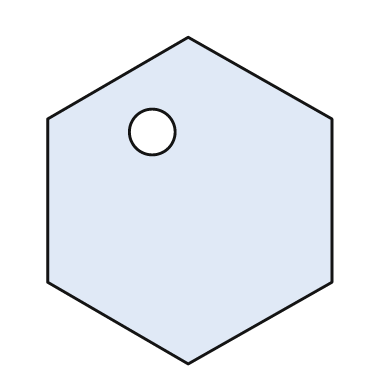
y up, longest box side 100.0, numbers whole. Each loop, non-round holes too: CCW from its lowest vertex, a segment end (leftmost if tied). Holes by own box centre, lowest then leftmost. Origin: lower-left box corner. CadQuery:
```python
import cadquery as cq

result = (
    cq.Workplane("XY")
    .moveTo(43.0, 0.0)
    .lineTo(87.0, 25.0)
    .lineTo(87.0, 75.0)
    .lineTo(43.0, 100.0)
    .lineTo(0.0, 75.0)
    .lineTo(0.0, 25.0)
    .close()
    .moveTo(32.0, 71.0)
    .circle(7.0)
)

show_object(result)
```